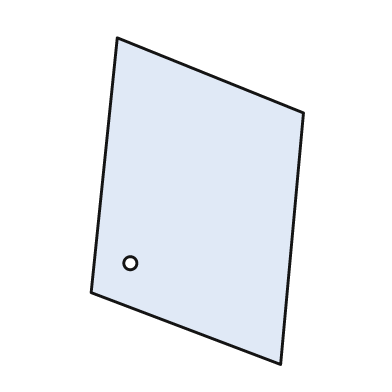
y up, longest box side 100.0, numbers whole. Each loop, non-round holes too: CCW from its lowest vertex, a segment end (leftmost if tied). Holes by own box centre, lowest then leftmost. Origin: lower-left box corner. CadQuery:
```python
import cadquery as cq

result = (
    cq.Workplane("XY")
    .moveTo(58.0, 0.0)
    .lineTo(65.0, 77.0)
    .lineTo(8.0, 100.0)
    .lineTo(0.0, 22.0)
    .close()
    .moveTo(12.0, 31.0)
    .circle(2.0)
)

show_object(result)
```